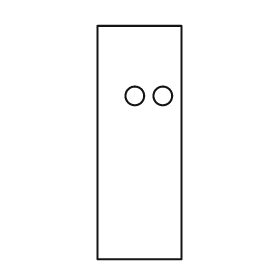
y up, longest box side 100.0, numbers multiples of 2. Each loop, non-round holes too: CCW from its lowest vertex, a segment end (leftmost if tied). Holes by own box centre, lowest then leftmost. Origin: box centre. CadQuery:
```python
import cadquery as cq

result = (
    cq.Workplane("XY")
    .moveTo(-18.0, -50.0)
    .lineTo(18.0, -50.0)
    .lineTo(18.0, 50.0)
    .lineTo(-18.0, 50.0)
    .close()
    .moveTo(-2.0, 20.0)
    .circle(4.0)
    .moveTo(10.0, 20.0)
    .circle(4.0)
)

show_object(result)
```